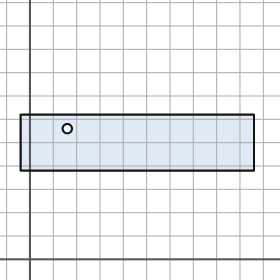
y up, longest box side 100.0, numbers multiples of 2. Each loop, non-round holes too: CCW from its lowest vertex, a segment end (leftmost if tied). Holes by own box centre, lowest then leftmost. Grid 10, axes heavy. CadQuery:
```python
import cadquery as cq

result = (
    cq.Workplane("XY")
    .moveTo(-4.0, 38.0)
    .lineTo(96.0, 38.0)
    .lineTo(96.0, 62.0)
    .lineTo(-4.0, 62.0)
    .close()
    .moveTo(16.0, 56.0)
    .circle(2.0)
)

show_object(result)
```